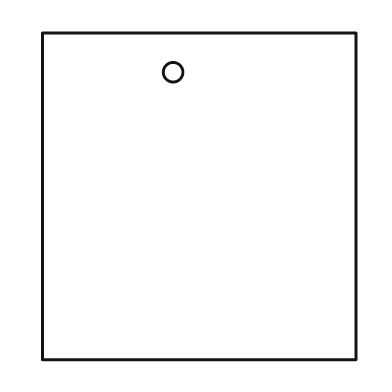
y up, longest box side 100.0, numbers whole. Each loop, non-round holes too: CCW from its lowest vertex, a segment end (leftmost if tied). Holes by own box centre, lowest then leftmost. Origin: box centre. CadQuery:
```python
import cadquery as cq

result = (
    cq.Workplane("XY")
    .moveTo(-48.0, -50.0)
    .lineTo(48.0, -50.0)
    .lineTo(48.0, 50.0)
    .lineTo(-48.0, 50.0)
    .close()
    .moveTo(-8.0, 38.0)
    .circle(3.0)
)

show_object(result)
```